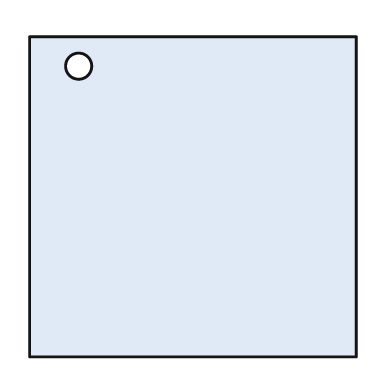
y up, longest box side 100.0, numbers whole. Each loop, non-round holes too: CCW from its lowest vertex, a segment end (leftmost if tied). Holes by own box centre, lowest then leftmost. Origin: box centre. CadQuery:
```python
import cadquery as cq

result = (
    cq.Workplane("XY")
    .moveTo(-50.0, -49.0)
    .lineTo(50.0, -49.0)
    .lineTo(50.0, 49.0)
    .lineTo(-50.0, 49.0)
    .close()
    .moveTo(-35.0, 40.0)
    .circle(4.0)
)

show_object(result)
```